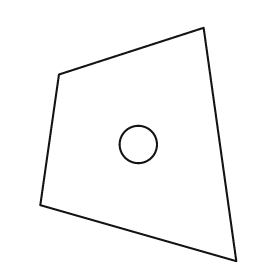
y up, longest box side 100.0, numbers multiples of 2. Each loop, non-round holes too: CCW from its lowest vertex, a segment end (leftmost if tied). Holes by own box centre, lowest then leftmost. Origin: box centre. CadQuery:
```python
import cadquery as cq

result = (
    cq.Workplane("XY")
    .moveTo(42.0, -50.0)
    .lineTo(28.0, 50.0)
    .lineTo(-34.0, 30.0)
    .lineTo(-42.0, -26.0)
    .close()
    .moveTo(0.0, 0.0)
    .circle(8.0)
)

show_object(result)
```